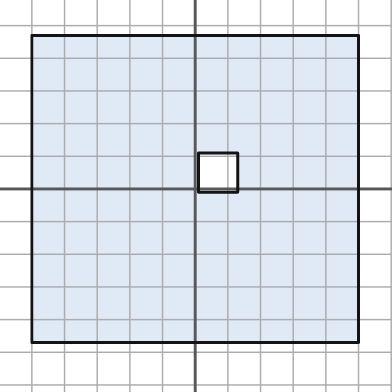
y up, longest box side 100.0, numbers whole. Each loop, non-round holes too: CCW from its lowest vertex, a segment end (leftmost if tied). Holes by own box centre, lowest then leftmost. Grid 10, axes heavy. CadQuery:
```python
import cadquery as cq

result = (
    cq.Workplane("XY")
    .moveTo(-50.0, -47.0)
    .lineTo(50.0, -47.0)
    .lineTo(50.0, 47.0)
    .lineTo(-50.0, 47.0)
    .close()
    .moveTo(1.0, -1.0)
    .lineTo(13.0, -1.0)
    .lineTo(13.0, 11.0)
    .lineTo(1.0, 11.0)
    .close()
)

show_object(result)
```